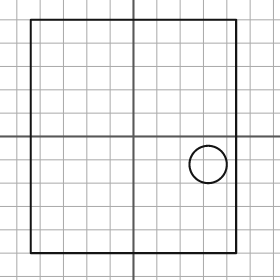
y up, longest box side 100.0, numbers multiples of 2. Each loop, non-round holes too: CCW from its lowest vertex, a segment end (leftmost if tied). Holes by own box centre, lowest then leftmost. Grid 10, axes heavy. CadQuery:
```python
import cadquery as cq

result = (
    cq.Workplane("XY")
    .moveTo(-44.0, -50.0)
    .lineTo(44.0, -50.0)
    .lineTo(44.0, 50.0)
    .lineTo(-44.0, 50.0)
    .close()
    .moveTo(32.0, -12.0)
    .circle(8.0)
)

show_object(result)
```